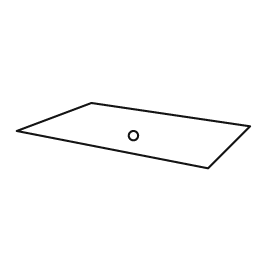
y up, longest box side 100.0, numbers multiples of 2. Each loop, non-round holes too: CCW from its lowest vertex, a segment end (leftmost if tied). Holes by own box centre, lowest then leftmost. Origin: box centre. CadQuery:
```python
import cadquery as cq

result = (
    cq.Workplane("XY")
    .moveTo(32.0, -14.0)
    .lineTo(50.0, 4.0)
    .lineTo(-18.0, 14.0)
    .lineTo(-50.0, 2.0)
    .close()
    .moveTo(0.0, 0.0)
    .circle(2.0)
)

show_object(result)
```